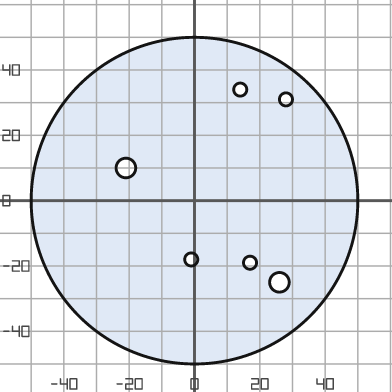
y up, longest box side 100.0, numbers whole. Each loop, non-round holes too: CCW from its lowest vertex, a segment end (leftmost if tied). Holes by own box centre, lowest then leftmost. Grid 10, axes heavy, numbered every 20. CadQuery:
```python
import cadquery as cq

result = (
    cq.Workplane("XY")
    .moveTo(0.0, 0.0)
    .circle(50.0)
    .moveTo(26.0, -25.0)
    .circle(3.0)
    .moveTo(17.0, -19.0)
    .circle(2.0)
    .moveTo(-1.0, -18.0)
    .circle(2.0)
    .moveTo(-21.0, 10.0)
    .circle(3.0)
    .moveTo(28.0, 31.0)
    .circle(2.0)
    .moveTo(14.0, 34.0)
    .circle(2.0)
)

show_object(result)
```